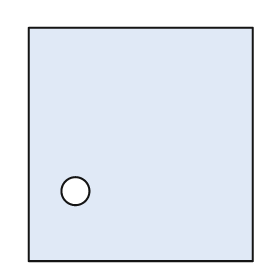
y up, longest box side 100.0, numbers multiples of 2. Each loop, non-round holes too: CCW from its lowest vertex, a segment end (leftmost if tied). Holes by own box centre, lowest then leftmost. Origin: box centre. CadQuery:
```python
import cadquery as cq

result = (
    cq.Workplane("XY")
    .moveTo(-48.0, -50.0)
    .lineTo(48.0, -50.0)
    .lineTo(48.0, 50.0)
    .lineTo(-48.0, 50.0)
    .close()
    .moveTo(-28.0, -20.0)
    .circle(6.0)
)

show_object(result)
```